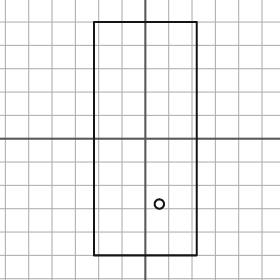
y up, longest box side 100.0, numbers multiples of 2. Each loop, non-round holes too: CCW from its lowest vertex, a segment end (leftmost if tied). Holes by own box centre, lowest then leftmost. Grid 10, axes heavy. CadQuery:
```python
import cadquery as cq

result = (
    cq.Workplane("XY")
    .moveTo(-22.0, -50.0)
    .lineTo(22.0, -50.0)
    .lineTo(22.0, 50.0)
    .lineTo(-22.0, 50.0)
    .close()
    .moveTo(6.0, -28.0)
    .circle(2.0)
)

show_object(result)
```